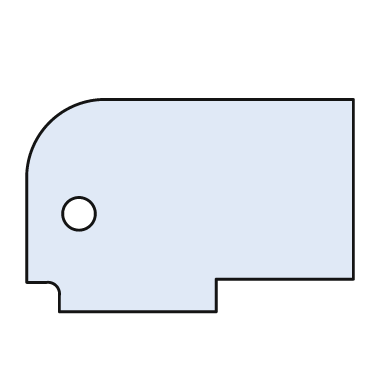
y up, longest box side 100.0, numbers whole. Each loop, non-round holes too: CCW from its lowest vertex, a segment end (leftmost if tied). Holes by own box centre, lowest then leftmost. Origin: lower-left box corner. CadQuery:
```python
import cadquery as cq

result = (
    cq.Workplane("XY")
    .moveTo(10.0, 0.0)
    .lineTo(58.0, 0.0)
    .lineTo(58.0, 10.0)
    .lineTo(100.0, 10.0)
    .lineTo(100.0, 65.0)
    .lineTo(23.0, 65.0)
    .threePointArc((7.0, 58.0), (0.0, 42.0))
    .lineTo(0.0, 9.0)
    .lineTo(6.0, 9.0)
    .threePointArc((9.0, 8.0), (10.0, 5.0))
    .close()
    .moveTo(16.0, 30.0)
    .circle(5.0)
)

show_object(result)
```